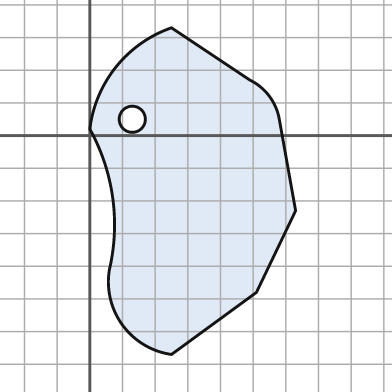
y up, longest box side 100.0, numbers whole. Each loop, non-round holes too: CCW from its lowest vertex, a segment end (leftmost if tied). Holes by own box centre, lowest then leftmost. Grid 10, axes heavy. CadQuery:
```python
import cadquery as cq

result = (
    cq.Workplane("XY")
    .moveTo(25.0, -67.0)
    .lineTo(51.0, -48.0)
    .lineTo(63.0, -23.0)
    .lineTo(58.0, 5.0)
    .threePointArc((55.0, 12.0), (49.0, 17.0))
    .lineTo(25.0, 33.0)
    .threePointArc((8.0, 21.0), (0.0, 2.0))
    .threePointArc((7.0, -19.0), (6.0, -41.0))
    .threePointArc((10.0, -58.0), (25.0, -67.0))
    .close()
    .moveTo(13.0, 5.0)
    .circle(4.0)
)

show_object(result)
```